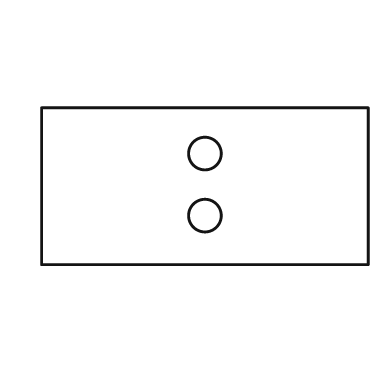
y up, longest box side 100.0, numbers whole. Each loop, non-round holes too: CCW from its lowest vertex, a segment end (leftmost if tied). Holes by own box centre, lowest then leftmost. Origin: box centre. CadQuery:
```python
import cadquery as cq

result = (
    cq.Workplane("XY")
    .moveTo(-50.0, -24.0)
    .lineTo(50.0, -24.0)
    .lineTo(50.0, 24.0)
    .lineTo(-50.0, 24.0)
    .close()
    .moveTo(0.0, -9.0)
    .circle(5.0)
    .moveTo(0.0, 10.0)
    .circle(5.0)
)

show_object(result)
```